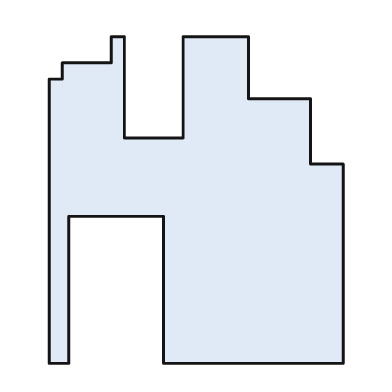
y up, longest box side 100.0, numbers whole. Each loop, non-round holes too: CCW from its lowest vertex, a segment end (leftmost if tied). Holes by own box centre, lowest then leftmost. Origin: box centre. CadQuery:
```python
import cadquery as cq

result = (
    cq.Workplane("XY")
    .moveTo(-45.0, -50.0)
    .lineTo(-39.0, -50.0)
    .lineTo(-39.0, -5.0)
    .lineTo(-10.0, -5.0)
    .lineTo(-10.0, -50.0)
    .lineTo(45.0, -50.0)
    .lineTo(45.0, 11.0)
    .lineTo(35.0, 11.0)
    .lineTo(35.0, 31.0)
    .lineTo(16.0, 31.0)
    .lineTo(16.0, 50.0)
    .lineTo(-4.0, 50.0)
    .lineTo(-4.0, 19.0)
    .lineTo(-22.0, 19.0)
    .lineTo(-22.0, 50.0)
    .lineTo(-26.0, 50.0)
    .lineTo(-26.0, 42.0)
    .lineTo(-41.0, 42.0)
    .lineTo(-41.0, 37.0)
    .lineTo(-45.0, 37.0)
    .close()
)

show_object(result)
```